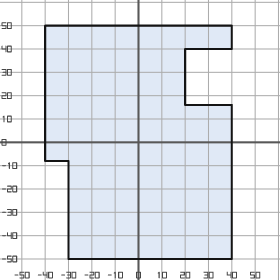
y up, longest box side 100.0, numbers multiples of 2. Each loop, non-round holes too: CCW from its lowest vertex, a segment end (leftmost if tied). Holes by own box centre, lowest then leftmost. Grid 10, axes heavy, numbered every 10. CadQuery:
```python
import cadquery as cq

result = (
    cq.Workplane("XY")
    .moveTo(-30.0, -50.0)
    .lineTo(40.0, -50.0)
    .lineTo(40.0, 16.0)
    .lineTo(20.0, 16.0)
    .lineTo(20.0, 40.0)
    .lineTo(40.0, 40.0)
    .lineTo(40.0, 50.0)
    .lineTo(-40.0, 50.0)
    .lineTo(-40.0, -8.0)
    .lineTo(-30.0, -8.0)
    .close()
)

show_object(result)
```